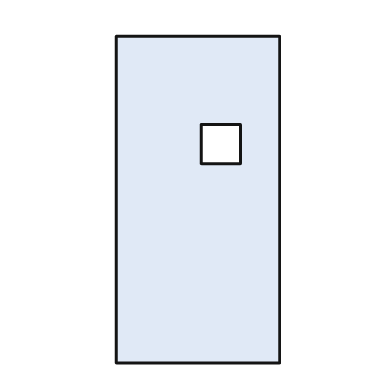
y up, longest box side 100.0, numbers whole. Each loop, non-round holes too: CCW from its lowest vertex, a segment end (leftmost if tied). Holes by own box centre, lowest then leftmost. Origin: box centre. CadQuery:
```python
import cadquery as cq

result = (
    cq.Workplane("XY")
    .moveTo(-25.0, -50.0)
    .lineTo(25.0, -50.0)
    .lineTo(25.0, 50.0)
    .lineTo(-25.0, 50.0)
    .close()
    .moveTo(1.0, 11.0)
    .lineTo(13.0, 11.0)
    .lineTo(13.0, 23.0)
    .lineTo(1.0, 23.0)
    .close()
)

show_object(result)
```